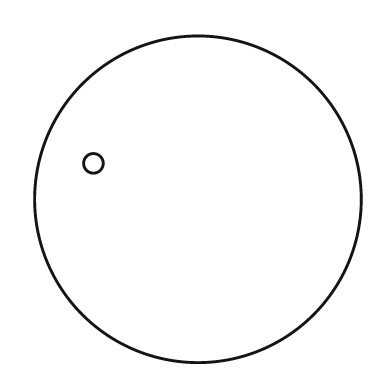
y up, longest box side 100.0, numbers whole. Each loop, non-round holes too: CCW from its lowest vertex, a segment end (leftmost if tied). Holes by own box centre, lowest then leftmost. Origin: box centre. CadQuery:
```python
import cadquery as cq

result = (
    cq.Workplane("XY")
    .moveTo(0.0, 0.0)
    .circle(50.0)
    .moveTo(-32.0, 11.0)
    .circle(3.0)
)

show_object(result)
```